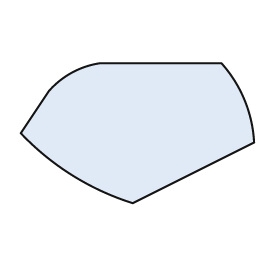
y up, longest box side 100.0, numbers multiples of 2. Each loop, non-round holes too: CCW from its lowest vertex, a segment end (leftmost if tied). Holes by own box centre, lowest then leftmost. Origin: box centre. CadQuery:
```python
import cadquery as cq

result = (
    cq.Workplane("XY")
    .moveTo(-2.0, -30.0)
    .lineTo(50.0, -4.0)
    .threePointArc((46.0, 14.0), (36.0, 30.0))
    .lineTo(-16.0, 30.0)
    .threePointArc((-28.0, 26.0), (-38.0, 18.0))
    .lineTo(-50.0, 0.0)
    .threePointArc((-28.0, -18.0), (-2.0, -30.0))
    .close()
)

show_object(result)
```